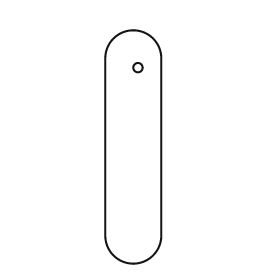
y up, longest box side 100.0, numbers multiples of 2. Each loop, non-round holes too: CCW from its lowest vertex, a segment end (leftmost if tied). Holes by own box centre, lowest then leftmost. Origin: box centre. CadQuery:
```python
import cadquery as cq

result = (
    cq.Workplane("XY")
    .moveTo(-12.0, -38.0)
    .threePointArc((0.0, -50.0), (12.0, -38.0))
    .lineTo(12.0, 38.0)
    .threePointArc((0.0, 50.0), (-12.0, 38.0))
    .close()
    .moveTo(2.0, 34.0)
    .circle(2.0)
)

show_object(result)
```